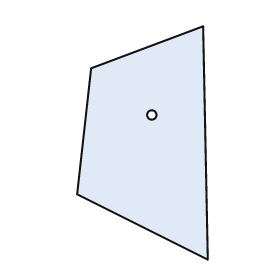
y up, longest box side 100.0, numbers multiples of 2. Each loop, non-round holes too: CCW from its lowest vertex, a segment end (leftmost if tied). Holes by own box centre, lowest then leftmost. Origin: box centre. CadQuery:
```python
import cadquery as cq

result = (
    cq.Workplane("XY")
    .moveTo(28.0, -50.0)
    .lineTo(26.0, 50.0)
    .lineTo(-22.0, 32.0)
    .lineTo(-28.0, -22.0)
    .close()
    .moveTo(4.0, 12.0)
    .circle(2.0)
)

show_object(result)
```